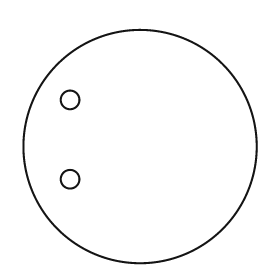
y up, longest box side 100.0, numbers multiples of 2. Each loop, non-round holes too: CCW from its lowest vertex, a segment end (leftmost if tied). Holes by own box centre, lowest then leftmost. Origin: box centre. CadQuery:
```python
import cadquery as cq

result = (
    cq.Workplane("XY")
    .moveTo(0.0, 0.0)
    .circle(50.0)
    .moveTo(-30.0, -14.0)
    .circle(4.0)
    .moveTo(-30.0, 20.0)
    .circle(4.0)
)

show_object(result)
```